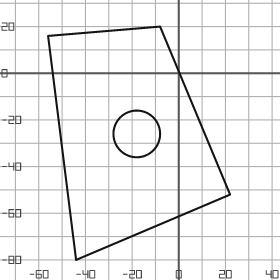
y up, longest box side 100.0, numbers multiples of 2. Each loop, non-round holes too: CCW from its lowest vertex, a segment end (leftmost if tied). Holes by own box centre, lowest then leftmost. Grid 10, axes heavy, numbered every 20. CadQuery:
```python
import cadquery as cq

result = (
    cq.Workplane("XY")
    .moveTo(-44.0, -80.0)
    .lineTo(22.0, -52.0)
    .lineTo(-8.0, 20.0)
    .lineTo(-56.0, 16.0)
    .close()
    .moveTo(-18.0, -26.0)
    .circle(10.0)
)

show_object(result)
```